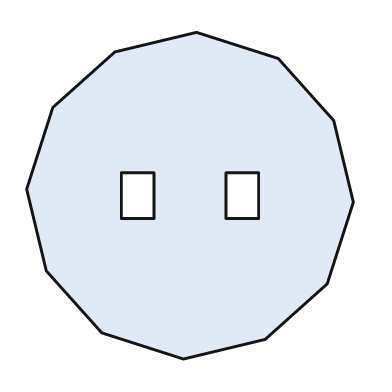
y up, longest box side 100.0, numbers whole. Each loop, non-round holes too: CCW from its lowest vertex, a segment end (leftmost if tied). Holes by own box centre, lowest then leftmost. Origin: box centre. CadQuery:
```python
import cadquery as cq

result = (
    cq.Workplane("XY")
    .moveTo(-2.0, -50.0)
    .lineTo(23.0, -44.0)
    .lineTo(42.0, -27.0)
    .lineTo(50.0, -2.0)
    .lineTo(44.0, 23.0)
    .lineTo(27.0, 42.0)
    .lineTo(2.0, 50.0)
    .lineTo(-23.0, 44.0)
    .lineTo(-42.0, 27.0)
    .lineTo(-50.0, 2.0)
    .lineTo(-44.0, -23.0)
    .lineTo(-27.0, -42.0)
    .close()
    .moveTo(-21.0, -7.0)
    .lineTo(-11.0, -7.0)
    .lineTo(-11.0, 7.0)
    .lineTo(-21.0, 7.0)
    .close()
    .moveTo(11.0, -7.0)
    .lineTo(21.0, -7.0)
    .lineTo(21.0, 7.0)
    .lineTo(11.0, 7.0)
    .close()
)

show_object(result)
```